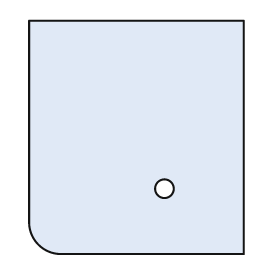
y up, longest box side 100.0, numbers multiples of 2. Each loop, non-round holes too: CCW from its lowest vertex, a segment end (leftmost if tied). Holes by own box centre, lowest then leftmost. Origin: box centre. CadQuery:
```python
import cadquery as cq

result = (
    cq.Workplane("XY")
    .moveTo(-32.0, -50.0)
    .lineTo(46.0, -50.0)
    .lineTo(46.0, 50.0)
    .lineTo(-46.0, 50.0)
    .lineTo(-46.0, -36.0)
    .threePointArc((-42.0, -46.0), (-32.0, -50.0))
    .close()
    .moveTo(12.0, -22.0)
    .circle(4.0)
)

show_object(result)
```